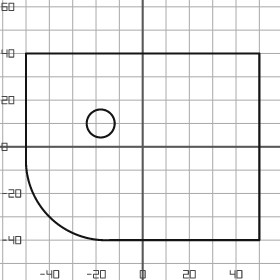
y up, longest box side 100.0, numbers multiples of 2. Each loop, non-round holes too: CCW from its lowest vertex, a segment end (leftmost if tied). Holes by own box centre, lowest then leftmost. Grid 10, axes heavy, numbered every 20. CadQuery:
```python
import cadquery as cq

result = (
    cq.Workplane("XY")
    .moveTo(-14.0, -40.0)
    .lineTo(50.0, -40.0)
    .lineTo(50.0, 40.0)
    .lineTo(-50.0, 40.0)
    .lineTo(-50.0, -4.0)
    .threePointArc((-40.0, -30.0), (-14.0, -40.0))
    .close()
    .moveTo(-18.0, 10.0)
    .circle(6.0)
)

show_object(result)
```